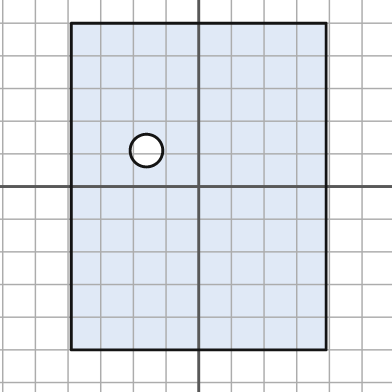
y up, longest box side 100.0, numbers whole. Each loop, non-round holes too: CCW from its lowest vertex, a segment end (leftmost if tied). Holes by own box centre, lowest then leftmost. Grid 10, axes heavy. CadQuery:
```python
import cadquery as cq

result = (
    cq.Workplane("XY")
    .moveTo(-39.0, -50.0)
    .lineTo(39.0, -50.0)
    .lineTo(39.0, 50.0)
    .lineTo(-39.0, 50.0)
    .close()
    .moveTo(-16.0, 11.0)
    .circle(5.0)
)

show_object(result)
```